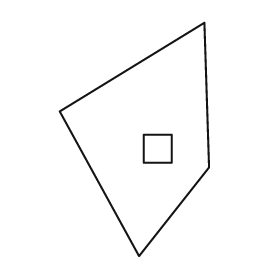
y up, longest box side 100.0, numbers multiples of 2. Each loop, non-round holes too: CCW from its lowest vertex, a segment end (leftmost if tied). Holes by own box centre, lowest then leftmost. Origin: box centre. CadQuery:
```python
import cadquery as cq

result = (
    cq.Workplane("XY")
    .moveTo(2.0, -50.0)
    .lineTo(32.0, -12.0)
    .lineTo(30.0, 50.0)
    .lineTo(-32.0, 12.0)
    .close()
    .moveTo(4.0, -10.0)
    .lineTo(16.0, -10.0)
    .lineTo(16.0, 2.0)
    .lineTo(4.0, 2.0)
    .close()
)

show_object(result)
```